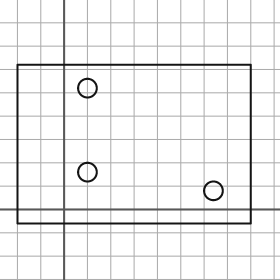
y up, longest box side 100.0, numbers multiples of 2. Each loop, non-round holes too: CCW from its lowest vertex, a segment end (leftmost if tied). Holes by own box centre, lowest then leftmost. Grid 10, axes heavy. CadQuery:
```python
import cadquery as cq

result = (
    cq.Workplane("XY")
    .moveTo(-20.0, -6.0)
    .lineTo(80.0, -6.0)
    .lineTo(80.0, 62.0)
    .lineTo(-20.0, 62.0)
    .close()
    .moveTo(64.0, 8.0)
    .circle(4.0)
    .moveTo(10.0, 16.0)
    .circle(4.0)
    .moveTo(10.0, 52.0)
    .circle(4.0)
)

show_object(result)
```